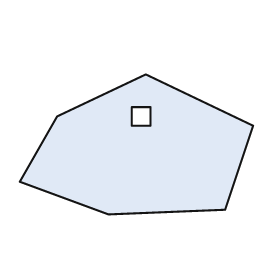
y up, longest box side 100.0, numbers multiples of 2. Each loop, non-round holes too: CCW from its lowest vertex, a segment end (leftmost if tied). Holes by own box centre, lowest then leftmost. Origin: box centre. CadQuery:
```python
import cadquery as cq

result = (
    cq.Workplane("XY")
    .moveTo(-12.0, -30.0)
    .lineTo(38.0, -28.0)
    .lineTo(50.0, 8.0)
    .lineTo(4.0, 30.0)
    .lineTo(-34.0, 12.0)
    .lineTo(-50.0, -16.0)
    .close()
    .moveTo(-2.0, 8.0)
    .lineTo(6.0, 8.0)
    .lineTo(6.0, 16.0)
    .lineTo(-2.0, 16.0)
    .close()
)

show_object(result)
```